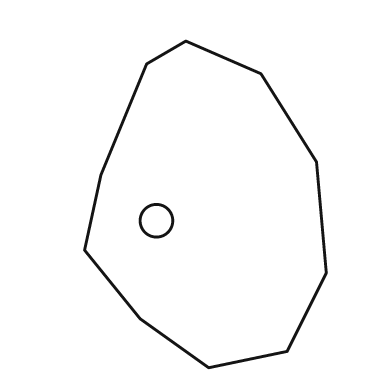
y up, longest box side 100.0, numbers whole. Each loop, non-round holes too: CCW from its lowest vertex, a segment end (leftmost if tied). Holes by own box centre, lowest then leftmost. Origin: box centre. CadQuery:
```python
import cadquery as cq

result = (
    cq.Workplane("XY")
    .moveTo(1.0, -50.0)
    .lineTo(25.0, -45.0)
    .lineTo(37.0, -21.0)
    .lineTo(34.0, 13.0)
    .lineTo(17.0, 40.0)
    .lineTo(-6.0, 50.0)
    .lineTo(-18.0, 43.0)
    .lineTo(-32.0, 9.0)
    .lineTo(-37.0, -14.0)
    .lineTo(-20.0, -35.0)
    .close()
    .moveTo(-15.0, -5.0)
    .circle(5.0)
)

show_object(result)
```